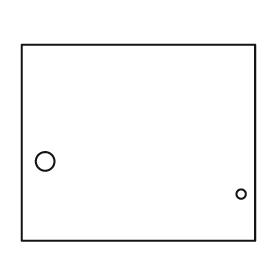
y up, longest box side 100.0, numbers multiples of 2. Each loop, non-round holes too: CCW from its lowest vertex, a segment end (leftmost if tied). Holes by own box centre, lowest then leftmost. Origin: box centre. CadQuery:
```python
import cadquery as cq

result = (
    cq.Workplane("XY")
    .moveTo(-50.0, -42.0)
    .lineTo(50.0, -42.0)
    .lineTo(50.0, 42.0)
    .lineTo(-50.0, 42.0)
    .close()
    .moveTo(44.0, -22.0)
    .circle(2.0)
    .moveTo(-40.0, -8.0)
    .circle(4.0)
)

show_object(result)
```